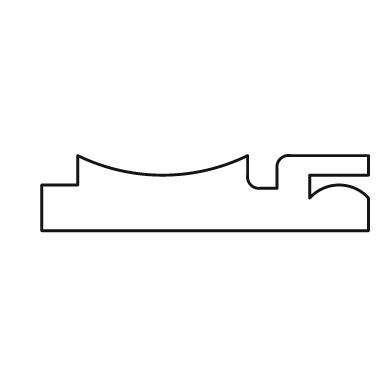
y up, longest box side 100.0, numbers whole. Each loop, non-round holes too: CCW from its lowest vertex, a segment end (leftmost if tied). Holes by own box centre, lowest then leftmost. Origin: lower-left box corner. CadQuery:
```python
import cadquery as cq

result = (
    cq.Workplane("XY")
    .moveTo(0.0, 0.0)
    .lineTo(100.0, 0.0)
    .lineTo(100.0, 10.0)
    .threePointArc((91.0, 14.0), (82.0, 10.0))
    .lineTo(82.0, 17.0)
    .lineTo(100.0, 17.0)
    .lineTo(100.0, 23.0)
    .lineTo(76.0, 23.0)
    .threePointArc((73.0, 22.0), (72.0, 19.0))
    .lineTo(72.0, 13.0)
    .lineTo(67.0, 13.0)
    .threePointArc((64.0, 14.0), (63.0, 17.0))
    .lineTo(63.0, 23.0)
    .threePointArc((37.0, 17.0), (11.0, 23.0))
    .lineTo(11.0, 14.0)
    .lineTo(0.0, 14.0)
    .close()
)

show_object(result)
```